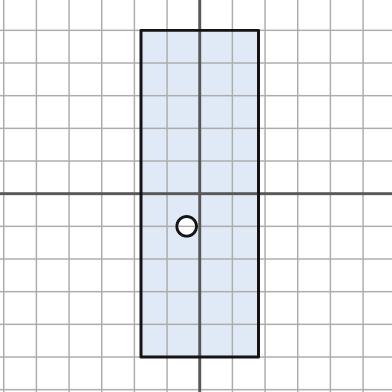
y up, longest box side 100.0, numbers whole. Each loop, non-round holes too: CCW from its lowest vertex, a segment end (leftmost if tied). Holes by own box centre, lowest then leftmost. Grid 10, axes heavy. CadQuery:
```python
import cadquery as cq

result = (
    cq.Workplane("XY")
    .moveTo(-18.0, -50.0)
    .lineTo(18.0, -50.0)
    .lineTo(18.0, 50.0)
    .lineTo(-18.0, 50.0)
    .close()
    .moveTo(-4.0, -10.0)
    .circle(3.0)
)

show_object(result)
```